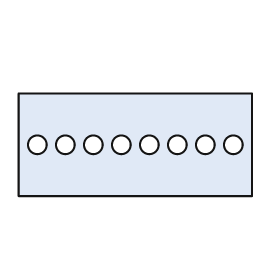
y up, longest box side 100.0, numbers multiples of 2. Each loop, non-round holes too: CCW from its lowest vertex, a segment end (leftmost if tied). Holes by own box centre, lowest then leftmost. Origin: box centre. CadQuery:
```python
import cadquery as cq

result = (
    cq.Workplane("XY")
    .moveTo(-50.0, -22.0)
    .lineTo(50.0, -22.0)
    .lineTo(50.0, 22.0)
    .lineTo(-50.0, 22.0)
    .close()
    .moveTo(-42.0, 0.0)
    .circle(4.0)
    .moveTo(-30.0, 0.0)
    .circle(4.0)
    .moveTo(-18.0, 0.0)
    .circle(4.0)
    .moveTo(-6.0, 0.0)
    .circle(4.0)
    .moveTo(6.0, 0.0)
    .circle(4.0)
    .moveTo(18.0, 0.0)
    .circle(4.0)
    .moveTo(30.0, 0.0)
    .circle(4.0)
    .moveTo(42.0, 0.0)
    .circle(4.0)
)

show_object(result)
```